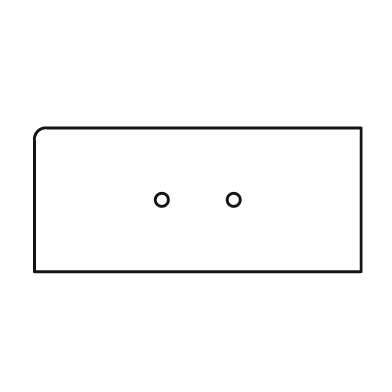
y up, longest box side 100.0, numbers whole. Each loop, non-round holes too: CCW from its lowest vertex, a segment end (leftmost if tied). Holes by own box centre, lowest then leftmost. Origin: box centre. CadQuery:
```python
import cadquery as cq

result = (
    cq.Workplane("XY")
    .moveTo(-50.0, -22.0)
    .lineTo(50.0, -22.0)
    .lineTo(50.0, 22.0)
    .lineTo(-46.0, 22.0)
    .threePointArc((-49.0, 21.0), (-50.0, 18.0))
    .close()
    .moveTo(-11.0, 0.0)
    .circle(2.0)
    .moveTo(11.0, 0.0)
    .circle(2.0)
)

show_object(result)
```